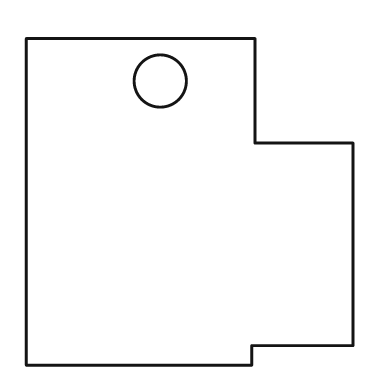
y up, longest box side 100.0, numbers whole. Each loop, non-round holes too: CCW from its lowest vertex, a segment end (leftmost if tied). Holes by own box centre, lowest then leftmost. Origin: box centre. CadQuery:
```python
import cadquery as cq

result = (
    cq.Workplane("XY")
    .moveTo(-50.0, -50.0)
    .lineTo(19.0, -50.0)
    .lineTo(19.0, -44.0)
    .lineTo(50.0, -44.0)
    .lineTo(50.0, 18.0)
    .lineTo(20.0, 18.0)
    .lineTo(20.0, 50.0)
    .lineTo(-50.0, 50.0)
    .close()
    .moveTo(-9.0, 37.0)
    .circle(8.0)
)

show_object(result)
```